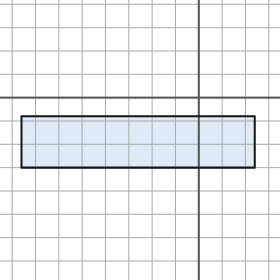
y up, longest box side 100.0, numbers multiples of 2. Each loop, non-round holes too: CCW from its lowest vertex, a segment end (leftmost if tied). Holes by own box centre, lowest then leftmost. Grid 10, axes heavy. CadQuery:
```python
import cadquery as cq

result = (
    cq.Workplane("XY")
    .moveTo(-76.0, -30.0)
    .lineTo(24.0, -30.0)
    .lineTo(24.0, -8.0)
    .lineTo(-76.0, -8.0)
    .close()
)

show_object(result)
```